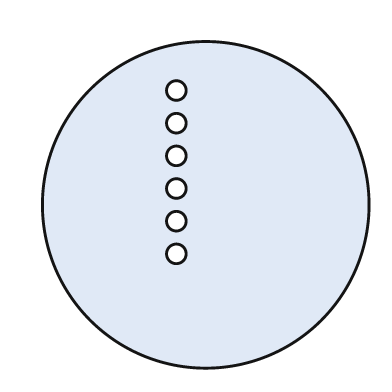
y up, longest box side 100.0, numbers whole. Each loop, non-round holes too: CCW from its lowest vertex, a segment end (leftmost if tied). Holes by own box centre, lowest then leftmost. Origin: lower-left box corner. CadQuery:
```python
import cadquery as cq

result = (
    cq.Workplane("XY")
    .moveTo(50.0, 50.0)
    .circle(50.0)
    .moveTo(41.0, 35.0)
    .circle(3.0)
    .moveTo(41.0, 45.0)
    .circle(3.0)
    .moveTo(41.0, 55.0)
    .circle(3.0)
    .moveTo(41.0, 65.0)
    .circle(3.0)
    .moveTo(41.0, 75.0)
    .circle(3.0)
    .moveTo(41.0, 85.0)
    .circle(3.0)
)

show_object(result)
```